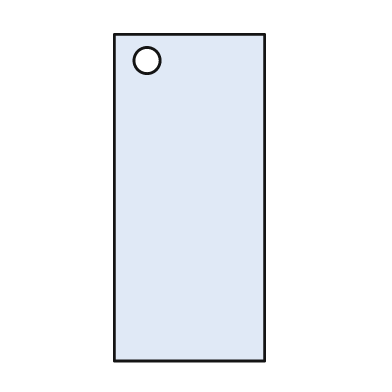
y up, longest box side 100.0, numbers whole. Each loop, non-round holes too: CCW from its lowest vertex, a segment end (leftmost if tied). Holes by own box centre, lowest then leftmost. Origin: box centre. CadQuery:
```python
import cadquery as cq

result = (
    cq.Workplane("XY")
    .moveTo(-23.0, -50.0)
    .lineTo(23.0, -50.0)
    .lineTo(23.0, 50.0)
    .lineTo(-23.0, 50.0)
    .close()
    .moveTo(-13.0, 42.0)
    .circle(4.0)
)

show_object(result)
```